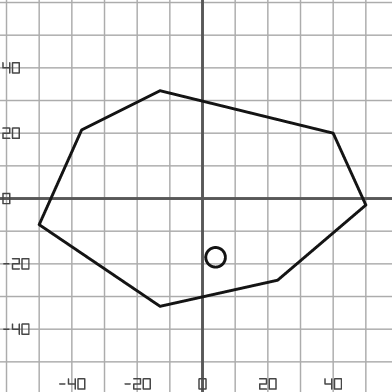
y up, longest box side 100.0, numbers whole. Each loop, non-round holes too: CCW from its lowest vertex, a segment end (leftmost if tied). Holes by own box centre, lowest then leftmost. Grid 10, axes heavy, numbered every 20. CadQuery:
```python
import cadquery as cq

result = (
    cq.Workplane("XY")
    .moveTo(-13.0, -33.0)
    .lineTo(23.0, -25.0)
    .lineTo(50.0, -2.0)
    .lineTo(40.0, 20.0)
    .lineTo(-13.0, 33.0)
    .lineTo(-37.0, 21.0)
    .lineTo(-50.0, -8.0)
    .close()
    .moveTo(4.0, -18.0)
    .circle(3.0)
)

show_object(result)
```